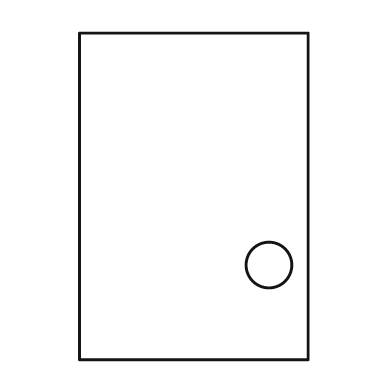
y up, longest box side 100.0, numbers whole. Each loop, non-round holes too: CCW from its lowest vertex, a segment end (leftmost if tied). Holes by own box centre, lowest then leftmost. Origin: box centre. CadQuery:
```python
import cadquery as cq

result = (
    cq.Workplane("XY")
    .moveTo(-35.0, -50.0)
    .lineTo(35.0, -50.0)
    .lineTo(35.0, 50.0)
    .lineTo(-35.0, 50.0)
    .close()
    .moveTo(23.0, -21.0)
    .circle(7.0)
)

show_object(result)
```